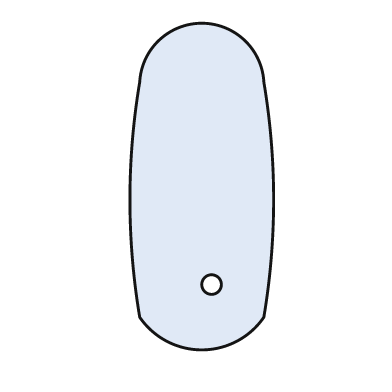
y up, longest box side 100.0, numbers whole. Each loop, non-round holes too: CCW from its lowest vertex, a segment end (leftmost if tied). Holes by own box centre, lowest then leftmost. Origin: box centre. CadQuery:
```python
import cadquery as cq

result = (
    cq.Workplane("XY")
    .moveTo(-19.0, -40.0)
    .threePointArc((0.0, -50.0), (19.0, -40.0))
    .threePointArc((22.0, -4.0), (19.0, 32.0))
    .threePointArc((0.0, 50.0), (-19.0, 32.0))
    .threePointArc((-22.0, -4.0), (-19.0, -40.0))
    .close()
    .moveTo(3.0, -30.0)
    .circle(3.0)
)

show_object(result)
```